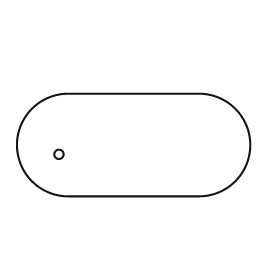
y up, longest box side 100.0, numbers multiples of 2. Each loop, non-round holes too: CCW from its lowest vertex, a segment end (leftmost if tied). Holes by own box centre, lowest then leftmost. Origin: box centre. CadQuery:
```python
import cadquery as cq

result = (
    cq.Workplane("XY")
    .moveTo(-28.0, -22.0)
    .lineTo(28.0, -22.0)
    .threePointArc((50.0, 0.0), (28.0, 22.0))
    .lineTo(-28.0, 22.0)
    .threePointArc((-50.0, 0.0), (-28.0, -22.0))
    .close()
    .moveTo(-32.0, -4.0)
    .circle(2.0)
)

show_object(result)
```